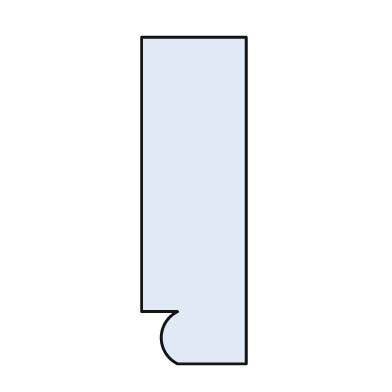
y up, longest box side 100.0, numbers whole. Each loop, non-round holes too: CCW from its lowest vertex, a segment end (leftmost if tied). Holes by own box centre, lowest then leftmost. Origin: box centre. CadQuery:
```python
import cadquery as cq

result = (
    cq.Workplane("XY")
    .moveTo(-5.0, -50.0)
    .lineTo(16.0, -50.0)
    .lineTo(16.0, 50.0)
    .lineTo(-16.0, 50.0)
    .lineTo(-16.0, -34.0)
    .lineTo(-5.0, -34.0)
    .threePointArc((-10.0, -42.0), (-5.0, -50.0))
    .close()
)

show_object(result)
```